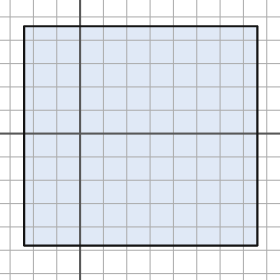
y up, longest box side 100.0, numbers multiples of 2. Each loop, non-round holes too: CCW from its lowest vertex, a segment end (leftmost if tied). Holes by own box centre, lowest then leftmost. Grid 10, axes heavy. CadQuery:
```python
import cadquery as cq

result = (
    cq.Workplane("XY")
    .moveTo(-24.0, -48.0)
    .lineTo(76.0, -48.0)
    .lineTo(76.0, 46.0)
    .lineTo(-24.0, 46.0)
    .close()
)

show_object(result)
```